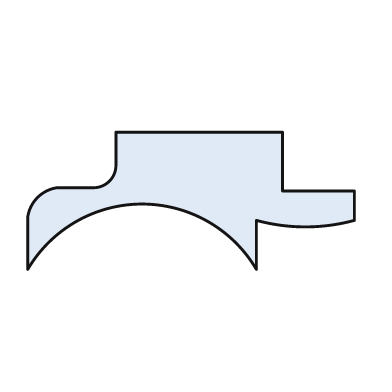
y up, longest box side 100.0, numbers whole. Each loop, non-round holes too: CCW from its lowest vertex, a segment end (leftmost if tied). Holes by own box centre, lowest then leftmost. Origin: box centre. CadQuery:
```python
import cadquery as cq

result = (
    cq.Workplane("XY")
    .moveTo(-50.0, -21.0)
    .threePointArc((-15.0, -1.0), (20.0, -21.0))
    .lineTo(20.0, -6.0)
    .threePointArc((35.0, -8.0), (50.0, -6.0))
    .lineTo(50.0, 3.0)
    .lineTo(28.0, 3.0)
    .lineTo(28.0, 21.0)
    .lineTo(-23.0, 21.0)
    .lineTo(-23.0, 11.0)
    .threePointArc((-25.0, 6.0), (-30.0, 4.0))
    .lineTo(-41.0, 4.0)
    .threePointArc((-47.0, 1.0), (-50.0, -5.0))
    .close()
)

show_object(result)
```